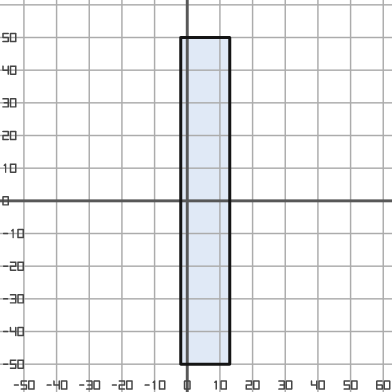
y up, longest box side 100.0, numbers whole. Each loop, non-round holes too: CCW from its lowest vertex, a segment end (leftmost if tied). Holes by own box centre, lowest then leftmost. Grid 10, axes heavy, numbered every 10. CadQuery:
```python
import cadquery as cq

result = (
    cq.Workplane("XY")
    .moveTo(-2.0, -50.0)
    .lineTo(13.0, -50.0)
    .lineTo(13.0, 50.0)
    .lineTo(-2.0, 50.0)
    .close()
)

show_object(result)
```